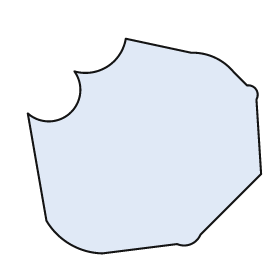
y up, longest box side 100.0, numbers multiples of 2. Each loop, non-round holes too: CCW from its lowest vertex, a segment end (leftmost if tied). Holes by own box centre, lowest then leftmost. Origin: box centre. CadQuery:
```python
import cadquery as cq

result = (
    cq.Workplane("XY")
    .moveTo(-18.0, -46.0)
    .lineTo(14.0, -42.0)
    .threePointArc((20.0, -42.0), (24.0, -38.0))
    .lineTo(50.0, -12.0)
    .lineTo(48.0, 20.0)
    .threePointArc((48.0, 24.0), (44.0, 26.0))
    .lineTo(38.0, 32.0)
    .threePointArc((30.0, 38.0), (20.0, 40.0))
    .lineTo(-8.0, 46.0)
    .threePointArc((-16.0, 34.0), (-30.0, 32.0))
    .threePointArc((-32.0, 14.0), (-50.0, 14.0))
    .lineTo(-42.0, -32.0)
    .threePointArc((-32.0, -42.0), (-18.0, -46.0))
    .close()
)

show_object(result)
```